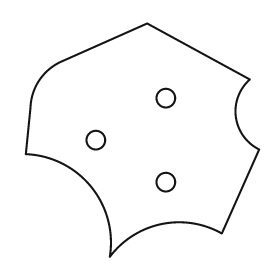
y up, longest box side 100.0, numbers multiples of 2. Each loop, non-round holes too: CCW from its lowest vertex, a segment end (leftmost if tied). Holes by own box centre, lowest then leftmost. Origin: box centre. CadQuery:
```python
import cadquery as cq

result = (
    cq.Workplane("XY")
    .moveTo(-14.0, -50.0)
    .threePointArc((8.0, -36.0), (34.0, -40.0))
    .lineTo(50.0, -4.0)
    .threePointArc((40.0, 10.0), (46.0, 26.0))
    .lineTo(2.0, 50.0)
    .lineTo(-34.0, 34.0)
    .threePointArc((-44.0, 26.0), (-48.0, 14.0))
    .lineTo(-50.0, -6.0)
    .threePointArc((-22.0, -20.0), (-14.0, -50.0))
    .close()
    .moveTo(10.0, -18.0)
    .circle(4.0)
    .moveTo(-20.0, 0.0)
    .circle(4.0)
    .moveTo(10.0, 18.0)
    .circle(4.0)
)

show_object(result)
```